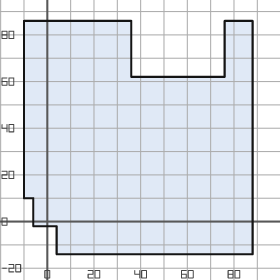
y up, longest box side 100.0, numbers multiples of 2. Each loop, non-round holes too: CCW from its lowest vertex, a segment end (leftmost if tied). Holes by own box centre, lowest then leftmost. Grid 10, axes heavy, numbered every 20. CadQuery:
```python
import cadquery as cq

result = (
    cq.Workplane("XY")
    .moveTo(4.0, -14.0)
    .lineTo(88.0, -14.0)
    .lineTo(88.0, 86.0)
    .lineTo(76.0, 86.0)
    .lineTo(76.0, 62.0)
    .lineTo(36.0, 62.0)
    .lineTo(36.0, 86.0)
    .lineTo(-10.0, 86.0)
    .lineTo(-10.0, 10.0)
    .lineTo(-6.0, 10.0)
    .lineTo(-6.0, -2.0)
    .lineTo(4.0, -2.0)
    .close()
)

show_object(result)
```